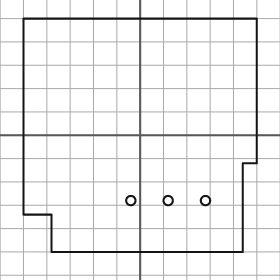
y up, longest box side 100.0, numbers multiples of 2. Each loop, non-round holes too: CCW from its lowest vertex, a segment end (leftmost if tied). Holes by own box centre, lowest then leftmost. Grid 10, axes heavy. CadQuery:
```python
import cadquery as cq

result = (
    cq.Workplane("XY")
    .moveTo(-38.0, -50.0)
    .lineTo(44.0, -50.0)
    .lineTo(44.0, -12.0)
    .lineTo(50.0, -12.0)
    .lineTo(50.0, 50.0)
    .lineTo(-50.0, 50.0)
    .lineTo(-50.0, -34.0)
    .lineTo(-38.0, -34.0)
    .close()
    .moveTo(-4.0, -28.0)
    .circle(2.0)
    .moveTo(12.0, -28.0)
    .circle(2.0)
    .moveTo(28.0, -28.0)
    .circle(2.0)
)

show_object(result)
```